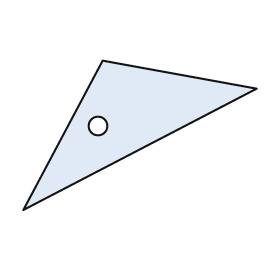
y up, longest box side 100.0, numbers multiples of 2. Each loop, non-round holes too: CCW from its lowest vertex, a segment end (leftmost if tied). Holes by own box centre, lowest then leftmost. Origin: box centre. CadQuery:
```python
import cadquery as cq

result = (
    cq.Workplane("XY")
    .moveTo(-50.0, -32.0)
    .lineTo(50.0, 20.0)
    .lineTo(-16.0, 32.0)
    .close()
    .moveTo(-18.0, 4.0)
    .circle(4.0)
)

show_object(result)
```